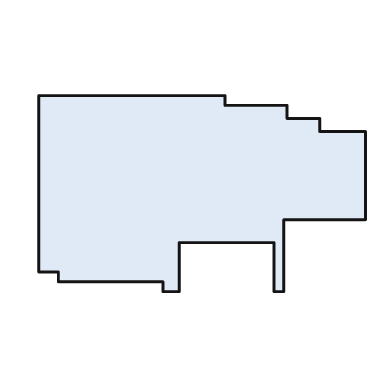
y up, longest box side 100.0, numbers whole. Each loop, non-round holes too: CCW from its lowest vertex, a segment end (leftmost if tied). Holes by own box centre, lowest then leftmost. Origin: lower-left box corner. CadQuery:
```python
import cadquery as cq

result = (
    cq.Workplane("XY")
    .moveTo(38.0, 0.0)
    .lineTo(43.0, 0.0)
    .lineTo(43.0, 15.0)
    .lineTo(72.0, 15.0)
    .lineTo(72.0, 0.0)
    .lineTo(75.0, 0.0)
    .lineTo(75.0, 22.0)
    .lineTo(100.0, 22.0)
    .lineTo(100.0, 49.0)
    .lineTo(86.0, 49.0)
    .lineTo(86.0, 53.0)
    .lineTo(76.0, 53.0)
    .lineTo(76.0, 57.0)
    .lineTo(57.0, 57.0)
    .lineTo(57.0, 60.0)
    .lineTo(0.0, 60.0)
    .lineTo(0.0, 6.0)
    .lineTo(6.0, 6.0)
    .lineTo(6.0, 3.0)
    .lineTo(38.0, 3.0)
    .close()
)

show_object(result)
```